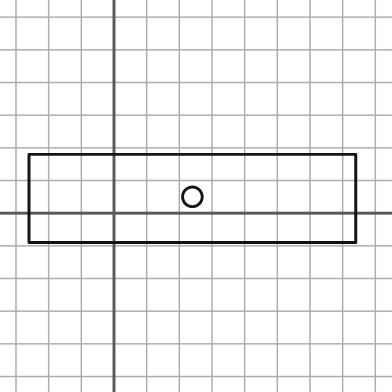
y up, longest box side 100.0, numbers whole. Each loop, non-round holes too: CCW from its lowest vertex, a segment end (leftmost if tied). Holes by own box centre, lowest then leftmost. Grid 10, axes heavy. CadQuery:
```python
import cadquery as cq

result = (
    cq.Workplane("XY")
    .moveTo(-26.0, -9.0)
    .lineTo(74.0, -9.0)
    .lineTo(74.0, 18.0)
    .lineTo(-26.0, 18.0)
    .close()
    .moveTo(24.0, 5.0)
    .circle(3.0)
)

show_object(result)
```